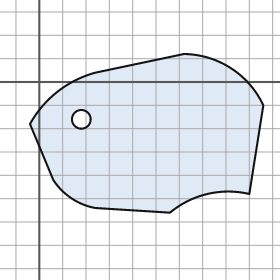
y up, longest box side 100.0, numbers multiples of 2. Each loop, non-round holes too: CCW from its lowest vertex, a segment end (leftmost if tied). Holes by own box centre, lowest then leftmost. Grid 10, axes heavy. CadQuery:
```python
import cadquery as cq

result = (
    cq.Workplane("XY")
    .moveTo(56.0, -56.0)
    .threePointArc((72.0, -48.0), (90.0, -48.0))
    .lineTo(96.0, -10.0)
    .threePointArc((82.0, 6.0), (62.0, 12.0))
    .lineTo(24.0, 4.0)
    .threePointArc((8.0, -4.0), (-4.0, -18.0))
    .lineTo(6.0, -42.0)
    .threePointArc((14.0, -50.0), (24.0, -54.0))
    .close()
    .moveTo(18.0, -16.0)
    .circle(4.0)
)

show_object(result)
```